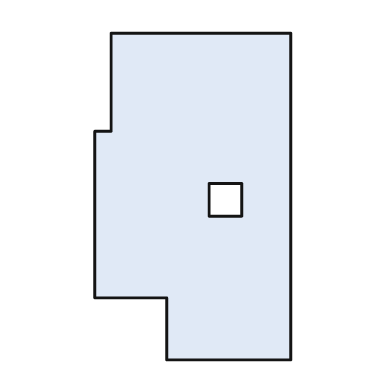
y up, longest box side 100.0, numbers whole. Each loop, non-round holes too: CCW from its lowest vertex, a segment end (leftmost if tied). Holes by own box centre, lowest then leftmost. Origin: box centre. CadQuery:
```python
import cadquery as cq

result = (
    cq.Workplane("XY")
    .moveTo(-8.0, -50.0)
    .lineTo(30.0, -50.0)
    .lineTo(30.0, 50.0)
    .lineTo(-25.0, 50.0)
    .lineTo(-25.0, 20.0)
    .lineTo(-30.0, 20.0)
    .lineTo(-30.0, -31.0)
    .lineTo(-8.0, -31.0)
    .close()
    .moveTo(5.0, -6.0)
    .lineTo(15.0, -6.0)
    .lineTo(15.0, 4.0)
    .lineTo(5.0, 4.0)
    .close()
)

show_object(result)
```